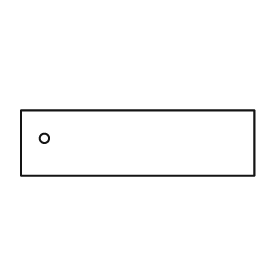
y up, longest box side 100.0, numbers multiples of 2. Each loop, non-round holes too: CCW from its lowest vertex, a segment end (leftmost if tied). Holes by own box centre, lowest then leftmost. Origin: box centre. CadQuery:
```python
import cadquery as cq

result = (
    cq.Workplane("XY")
    .moveTo(-50.0, -14.0)
    .lineTo(50.0, -14.0)
    .lineTo(50.0, 14.0)
    .lineTo(-50.0, 14.0)
    .close()
    .moveTo(-40.0, 2.0)
    .circle(2.0)
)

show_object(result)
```